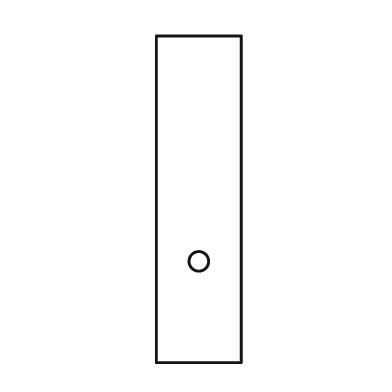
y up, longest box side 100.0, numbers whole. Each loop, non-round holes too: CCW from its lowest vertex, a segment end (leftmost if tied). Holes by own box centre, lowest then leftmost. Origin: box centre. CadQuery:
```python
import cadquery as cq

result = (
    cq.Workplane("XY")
    .moveTo(-13.0, -50.0)
    .lineTo(13.0, -50.0)
    .lineTo(13.0, 50.0)
    .lineTo(-13.0, 50.0)
    .close()
    .moveTo(0.0, -19.0)
    .circle(3.0)
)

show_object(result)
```